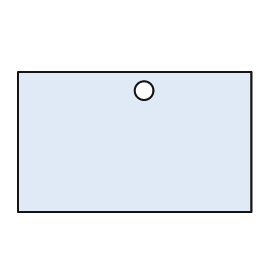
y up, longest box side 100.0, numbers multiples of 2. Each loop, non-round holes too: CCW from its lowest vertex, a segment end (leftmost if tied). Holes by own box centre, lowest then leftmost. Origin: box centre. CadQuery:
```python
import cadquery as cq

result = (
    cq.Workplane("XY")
    .moveTo(-50.0, -30.0)
    .lineTo(50.0, -30.0)
    .lineTo(50.0, 30.0)
    .lineTo(-50.0, 30.0)
    .close()
    .moveTo(4.0, 22.0)
    .circle(4.0)
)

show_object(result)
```